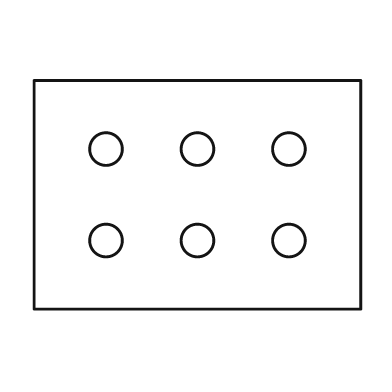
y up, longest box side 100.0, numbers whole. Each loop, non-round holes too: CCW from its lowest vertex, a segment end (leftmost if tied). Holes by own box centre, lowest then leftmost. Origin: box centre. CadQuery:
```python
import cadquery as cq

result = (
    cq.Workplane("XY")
    .moveTo(-50.0, -35.0)
    .lineTo(50.0, -35.0)
    .lineTo(50.0, 35.0)
    .lineTo(-50.0, 35.0)
    .close()
    .moveTo(-28.0, -14.0)
    .circle(5.0)
    .moveTo(0.0, -14.0)
    .circle(5.0)
    .moveTo(28.0, -14.0)
    .circle(5.0)
    .moveTo(-28.0, 14.0)
    .circle(5.0)
    .moveTo(0.0, 14.0)
    .circle(5.0)
    .moveTo(28.0, 14.0)
    .circle(5.0)
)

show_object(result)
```